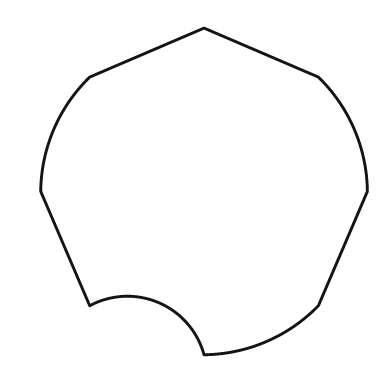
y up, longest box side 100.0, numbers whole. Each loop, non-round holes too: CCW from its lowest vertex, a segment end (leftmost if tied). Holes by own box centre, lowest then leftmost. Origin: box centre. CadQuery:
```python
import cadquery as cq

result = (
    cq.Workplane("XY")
    .moveTo(0.0, -50.0)
    .threePointArc((19.0, -46.0), (35.0, -35.0))
    .lineTo(50.0, 0.0)
    .threePointArc((46.0, 19.0), (35.0, 35.0))
    .lineTo(0.0, 50.0)
    .lineTo(-35.0, 35.0)
    .threePointArc((-46.0, 19.0), (-50.0, 0.0))
    .lineTo(-35.0, -35.0)
    .threePointArc((-14.0, -34.0), (0.0, -50.0))
    .close()
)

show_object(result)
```